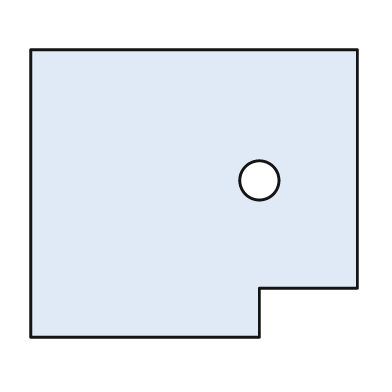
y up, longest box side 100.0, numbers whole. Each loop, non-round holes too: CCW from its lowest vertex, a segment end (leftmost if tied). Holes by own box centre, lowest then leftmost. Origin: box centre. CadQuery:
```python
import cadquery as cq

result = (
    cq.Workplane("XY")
    .moveTo(-50.0, -44.0)
    .lineTo(20.0, -44.0)
    .lineTo(20.0, -29.0)
    .lineTo(50.0, -29.0)
    .lineTo(50.0, 44.0)
    .lineTo(-50.0, 44.0)
    .close()
    .moveTo(20.0, 4.0)
    .circle(6.0)
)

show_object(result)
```